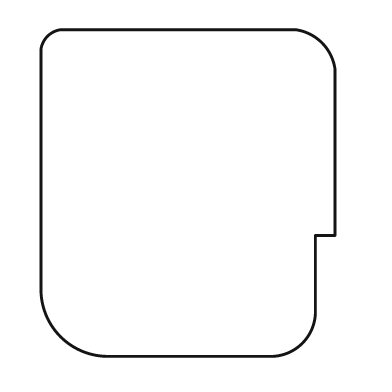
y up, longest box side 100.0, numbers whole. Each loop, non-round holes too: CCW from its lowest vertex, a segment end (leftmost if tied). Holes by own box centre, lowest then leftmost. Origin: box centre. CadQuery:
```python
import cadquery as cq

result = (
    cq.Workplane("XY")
    .moveTo(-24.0, -50.0)
    .lineTo(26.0, -50.0)
    .threePointArc((35.0, -46.0), (39.0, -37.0))
    .lineTo(39.0, -13.0)
    .lineTo(45.0, -13.0)
    .lineTo(45.0, 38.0)
    .threePointArc((41.0, 46.0), (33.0, 50.0))
    .lineTo(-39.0, 50.0)
    .threePointArc((-43.0, 48.0), (-45.0, 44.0))
    .lineTo(-45.0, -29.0)
    .threePointArc((-39.0, -44.0), (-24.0, -50.0))
    .close()
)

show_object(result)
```